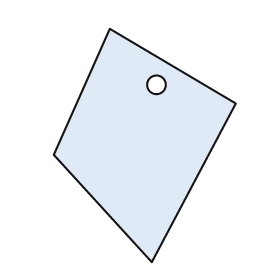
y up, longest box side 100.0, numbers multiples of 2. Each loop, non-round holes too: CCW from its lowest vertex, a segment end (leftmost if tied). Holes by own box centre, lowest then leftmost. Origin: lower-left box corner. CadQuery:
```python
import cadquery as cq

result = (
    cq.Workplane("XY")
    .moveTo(42.0, 0.0)
    .lineTo(78.0, 68.0)
    .lineTo(24.0, 100.0)
    .lineTo(0.0, 46.0)
    .close()
    .moveTo(44.0, 76.0)
    .circle(4.0)
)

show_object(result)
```